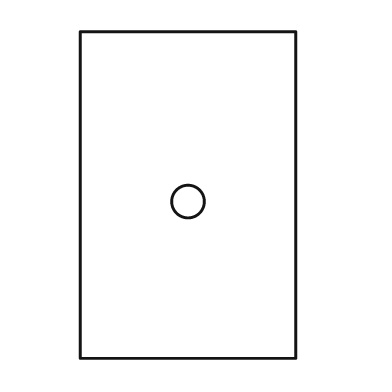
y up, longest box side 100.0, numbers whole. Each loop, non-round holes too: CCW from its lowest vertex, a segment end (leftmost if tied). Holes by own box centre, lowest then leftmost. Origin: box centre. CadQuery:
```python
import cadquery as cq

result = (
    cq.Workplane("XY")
    .moveTo(-33.0, -50.0)
    .lineTo(33.0, -50.0)
    .lineTo(33.0, 50.0)
    .lineTo(-33.0, 50.0)
    .close()
    .moveTo(0.0, -2.0)
    .circle(5.0)
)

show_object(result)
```